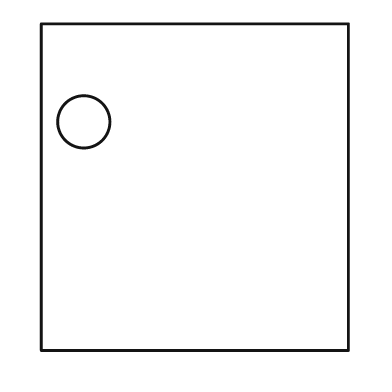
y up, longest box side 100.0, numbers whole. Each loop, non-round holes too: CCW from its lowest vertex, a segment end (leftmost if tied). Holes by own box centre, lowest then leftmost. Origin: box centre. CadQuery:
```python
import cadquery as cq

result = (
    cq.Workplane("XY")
    .moveTo(-47.0, -50.0)
    .lineTo(47.0, -50.0)
    .lineTo(47.0, 50.0)
    .lineTo(-47.0, 50.0)
    .close()
    .moveTo(-34.0, 20.0)
    .circle(8.0)
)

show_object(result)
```